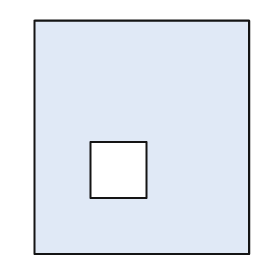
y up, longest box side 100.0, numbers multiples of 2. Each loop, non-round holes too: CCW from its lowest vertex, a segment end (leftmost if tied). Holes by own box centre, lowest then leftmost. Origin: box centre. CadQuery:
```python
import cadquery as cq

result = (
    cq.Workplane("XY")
    .moveTo(-46.0, -50.0)
    .lineTo(46.0, -50.0)
    .lineTo(46.0, 50.0)
    .lineTo(-46.0, 50.0)
    .close()
    .moveTo(-22.0, -26.0)
    .lineTo(2.0, -26.0)
    .lineTo(2.0, -2.0)
    .lineTo(-22.0, -2.0)
    .close()
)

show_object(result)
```